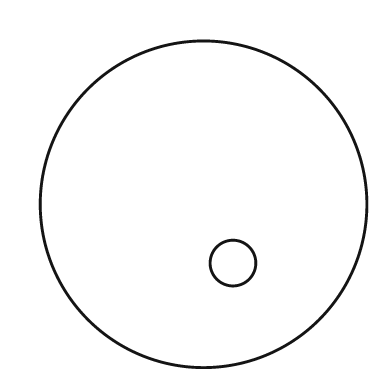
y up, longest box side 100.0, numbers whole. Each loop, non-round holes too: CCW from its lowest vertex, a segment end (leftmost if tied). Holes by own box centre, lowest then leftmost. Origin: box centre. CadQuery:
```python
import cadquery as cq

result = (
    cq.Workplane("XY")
    .moveTo(0.0, 0.0)
    .circle(50.0)
    .moveTo(9.0, -18.0)
    .circle(7.0)
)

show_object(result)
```